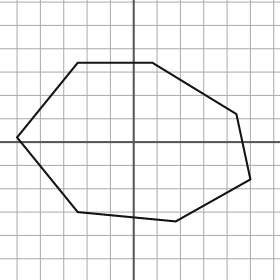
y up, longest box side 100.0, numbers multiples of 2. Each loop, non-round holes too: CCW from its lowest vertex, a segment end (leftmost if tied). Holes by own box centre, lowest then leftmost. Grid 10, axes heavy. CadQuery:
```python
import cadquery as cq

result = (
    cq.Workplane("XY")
    .moveTo(18.0, -34.0)
    .lineTo(50.0, -16.0)
    .lineTo(44.0, 12.0)
    .lineTo(8.0, 34.0)
    .lineTo(-24.0, 34.0)
    .lineTo(-50.0, 2.0)
    .lineTo(-24.0, -30.0)
    .close()
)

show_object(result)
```